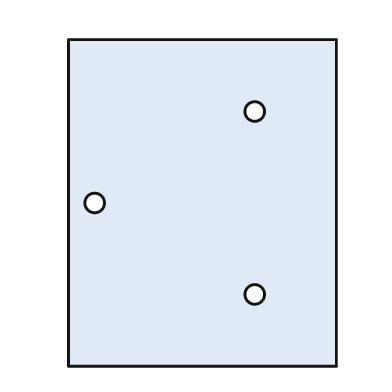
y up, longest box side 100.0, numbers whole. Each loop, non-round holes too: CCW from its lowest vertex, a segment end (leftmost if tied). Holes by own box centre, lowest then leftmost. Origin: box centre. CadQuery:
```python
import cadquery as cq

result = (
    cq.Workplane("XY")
    .moveTo(-41.0, -50.0)
    .lineTo(41.0, -50.0)
    .lineTo(41.0, 50.0)
    .lineTo(-41.0, 50.0)
    .close()
    .moveTo(16.0, -28.0)
    .circle(3.0)
    .moveTo(-33.0, 0.0)
    .circle(3.0)
    .moveTo(16.0, 28.0)
    .circle(3.0)
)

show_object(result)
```